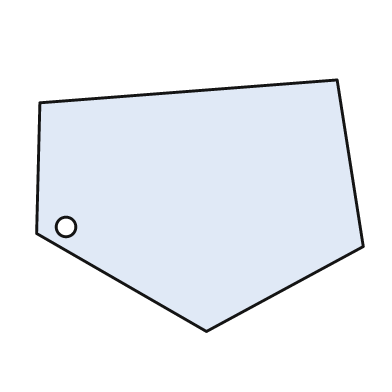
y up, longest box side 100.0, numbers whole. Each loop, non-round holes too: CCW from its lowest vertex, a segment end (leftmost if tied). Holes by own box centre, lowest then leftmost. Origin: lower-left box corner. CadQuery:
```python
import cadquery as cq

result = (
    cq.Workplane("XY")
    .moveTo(52.0, 0.0)
    .lineTo(100.0, 26.0)
    .lineTo(92.0, 77.0)
    .lineTo(1.0, 70.0)
    .lineTo(0.0, 30.0)
    .close()
    .moveTo(9.0, 32.0)
    .circle(3.0)
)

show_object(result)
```